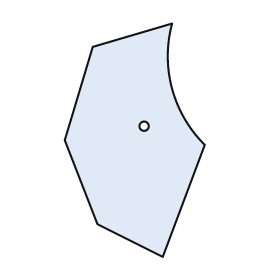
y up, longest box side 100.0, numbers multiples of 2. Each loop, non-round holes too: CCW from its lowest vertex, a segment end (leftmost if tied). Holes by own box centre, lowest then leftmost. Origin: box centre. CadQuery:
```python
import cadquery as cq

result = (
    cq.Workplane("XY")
    .moveTo(12.0, -50.0)
    .lineTo(30.0, -2.0)
    .threePointArc((16.0, 22.0), (16.0, 50.0))
    .lineTo(-18.0, 40.0)
    .lineTo(-30.0, 0.0)
    .lineTo(-16.0, -36.0)
    .close()
    .moveTo(4.0, 6.0)
    .circle(2.0)
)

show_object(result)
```